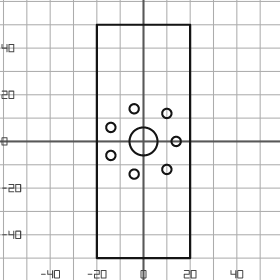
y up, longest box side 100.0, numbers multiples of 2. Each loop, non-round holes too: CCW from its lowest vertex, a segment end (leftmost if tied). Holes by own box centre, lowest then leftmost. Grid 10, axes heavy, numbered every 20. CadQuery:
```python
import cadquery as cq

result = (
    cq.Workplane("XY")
    .moveTo(-20.0, -50.0)
    .lineTo(20.0, -50.0)
    .lineTo(20.0, 50.0)
    .lineTo(-20.0, 50.0)
    .close()
    .moveTo(-4.0, -14.0)
    .circle(2.0)
    .moveTo(10.0, -12.0)
    .circle(2.0)
    .moveTo(-14.0, -6.0)
    .circle(2.0)
    .moveTo(0.0, 0.0)
    .circle(6.0)
    .moveTo(14.0, 0.0)
    .circle(2.0)
    .moveTo(-14.0, 6.0)
    .circle(2.0)
    .moveTo(10.0, 12.0)
    .circle(2.0)
    .moveTo(-4.0, 14.0)
    .circle(2.0)
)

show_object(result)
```